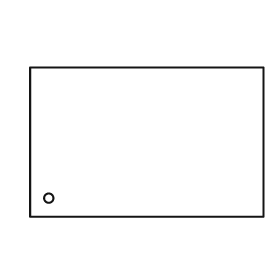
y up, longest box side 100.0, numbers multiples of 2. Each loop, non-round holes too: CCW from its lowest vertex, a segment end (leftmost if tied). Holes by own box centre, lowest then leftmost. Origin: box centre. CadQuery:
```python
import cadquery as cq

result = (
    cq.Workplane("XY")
    .moveTo(-50.0, -32.0)
    .lineTo(50.0, -32.0)
    .lineTo(50.0, 32.0)
    .lineTo(-50.0, 32.0)
    .close()
    .moveTo(-42.0, -24.0)
    .circle(2.0)
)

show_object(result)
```